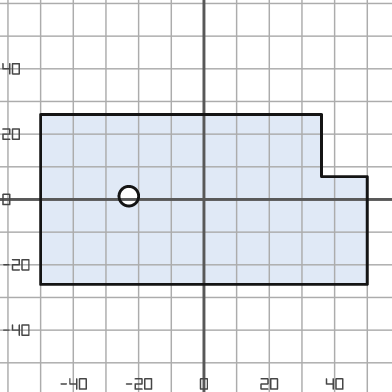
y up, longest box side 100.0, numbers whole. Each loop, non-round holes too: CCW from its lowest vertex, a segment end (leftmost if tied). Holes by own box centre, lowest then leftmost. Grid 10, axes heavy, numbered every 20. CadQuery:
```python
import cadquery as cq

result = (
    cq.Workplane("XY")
    .moveTo(-50.0, -26.0)
    .lineTo(50.0, -26.0)
    .lineTo(50.0, 7.0)
    .lineTo(36.0, 7.0)
    .lineTo(36.0, 26.0)
    .lineTo(-50.0, 26.0)
    .close()
    .moveTo(-23.0, 1.0)
    .circle(3.0)
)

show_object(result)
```